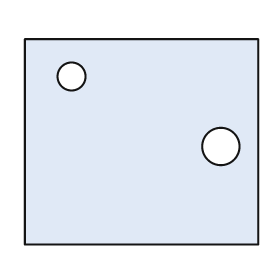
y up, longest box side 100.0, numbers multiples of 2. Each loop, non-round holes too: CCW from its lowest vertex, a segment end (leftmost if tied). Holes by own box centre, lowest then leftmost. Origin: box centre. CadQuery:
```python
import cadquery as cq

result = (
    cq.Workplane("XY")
    .moveTo(-50.0, -44.0)
    .lineTo(50.0, -44.0)
    .lineTo(50.0, 44.0)
    .lineTo(-50.0, 44.0)
    .close()
    .moveTo(34.0, -2.0)
    .circle(8.0)
    .moveTo(-30.0, 28.0)
    .circle(6.0)
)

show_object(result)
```